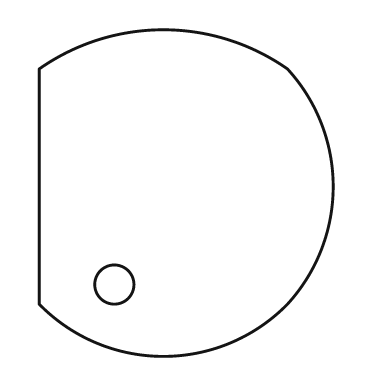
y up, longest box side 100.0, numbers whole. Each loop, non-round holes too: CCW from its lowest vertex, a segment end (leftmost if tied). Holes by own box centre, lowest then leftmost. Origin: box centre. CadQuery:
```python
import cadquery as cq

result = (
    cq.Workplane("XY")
    .moveTo(-45.0, -34.0)
    .threePointArc((-7.0, -50.0), (31.0, -34.0))
    .threePointArc((45.0, 2.0), (31.0, 38.0))
    .threePointArc((-7.0, 50.0), (-45.0, 38.0))
    .close()
    .moveTo(-22.0, -28.0)
    .circle(6.0)
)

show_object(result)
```